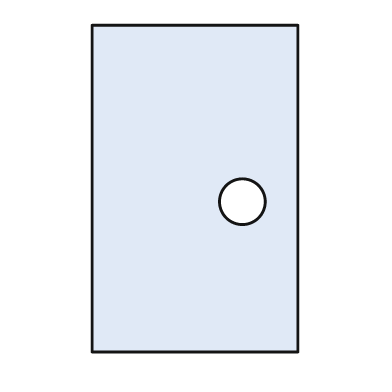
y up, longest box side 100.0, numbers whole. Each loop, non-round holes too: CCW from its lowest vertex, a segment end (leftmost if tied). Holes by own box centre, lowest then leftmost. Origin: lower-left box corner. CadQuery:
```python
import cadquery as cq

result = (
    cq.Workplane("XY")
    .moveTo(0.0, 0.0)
    .lineTo(63.0, 0.0)
    .lineTo(63.0, 100.0)
    .lineTo(0.0, 100.0)
    .close()
    .moveTo(46.0, 46.0)
    .circle(7.0)
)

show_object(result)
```